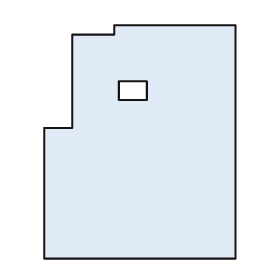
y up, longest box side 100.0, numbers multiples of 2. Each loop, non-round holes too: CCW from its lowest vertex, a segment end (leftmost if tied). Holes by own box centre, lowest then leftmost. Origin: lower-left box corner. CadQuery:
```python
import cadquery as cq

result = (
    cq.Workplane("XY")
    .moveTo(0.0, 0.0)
    .lineTo(82.0, 0.0)
    .lineTo(82.0, 100.0)
    .lineTo(30.0, 100.0)
    .lineTo(30.0, 96.0)
    .lineTo(12.0, 96.0)
    .lineTo(12.0, 56.0)
    .lineTo(0.0, 56.0)
    .close()
    .moveTo(32.0, 68.0)
    .lineTo(44.0, 68.0)
    .lineTo(44.0, 76.0)
    .lineTo(32.0, 76.0)
    .close()
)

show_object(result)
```